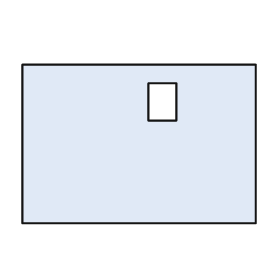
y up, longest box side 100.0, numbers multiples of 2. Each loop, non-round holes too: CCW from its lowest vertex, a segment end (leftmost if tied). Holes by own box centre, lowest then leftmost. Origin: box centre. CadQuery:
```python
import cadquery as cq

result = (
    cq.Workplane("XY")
    .moveTo(-50.0, -34.0)
    .lineTo(50.0, -34.0)
    .lineTo(50.0, 34.0)
    .lineTo(-50.0, 34.0)
    .close()
    .moveTo(4.0, 10.0)
    .lineTo(16.0, 10.0)
    .lineTo(16.0, 26.0)
    .lineTo(4.0, 26.0)
    .close()
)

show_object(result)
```